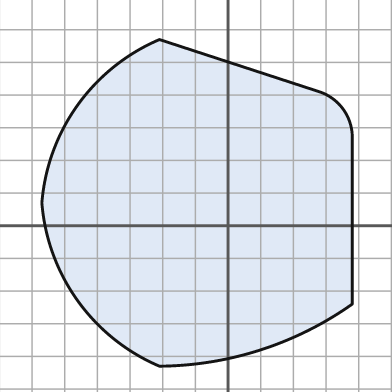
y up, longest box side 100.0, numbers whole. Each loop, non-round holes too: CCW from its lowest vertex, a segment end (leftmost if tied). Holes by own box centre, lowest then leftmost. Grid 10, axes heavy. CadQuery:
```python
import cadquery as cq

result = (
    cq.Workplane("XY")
    .moveTo(-21.0, -43.0)
    .threePointArc((10.0, -38.0), (38.0, -24.0))
    .lineTo(38.0, 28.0)
    .threePointArc((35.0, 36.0), (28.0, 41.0))
    .lineTo(-21.0, 57.0)
    .threePointArc((-46.0, 37.0), (-57.0, 7.0))
    .threePointArc((-46.0, -23.0), (-21.0, -43.0))
    .close()
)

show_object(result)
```